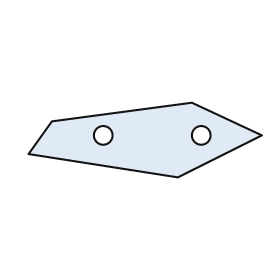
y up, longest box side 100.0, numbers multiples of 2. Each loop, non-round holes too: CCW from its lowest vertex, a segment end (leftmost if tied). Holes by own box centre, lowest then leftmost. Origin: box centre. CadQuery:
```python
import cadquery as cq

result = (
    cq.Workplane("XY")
    .moveTo(14.0, -16.0)
    .lineTo(50.0, 2.0)
    .lineTo(20.0, 16.0)
    .lineTo(-40.0, 8.0)
    .lineTo(-50.0, -6.0)
    .close()
    .moveTo(-18.0, 2.0)
    .circle(4.0)
    .moveTo(24.0, 2.0)
    .circle(4.0)
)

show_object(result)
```